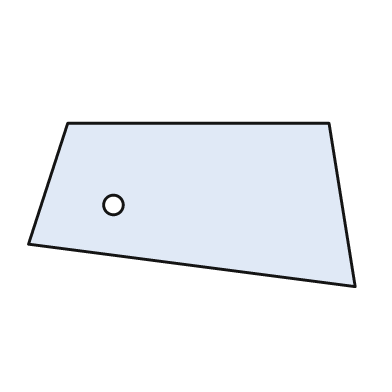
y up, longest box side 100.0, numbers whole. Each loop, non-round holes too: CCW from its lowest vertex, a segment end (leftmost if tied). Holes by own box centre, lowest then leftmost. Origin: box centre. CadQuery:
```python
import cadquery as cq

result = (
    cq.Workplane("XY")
    .moveTo(50.0, -25.0)
    .lineTo(42.0, 25.0)
    .lineTo(-38.0, 25.0)
    .lineTo(-50.0, -12.0)
    .close()
    .moveTo(-24.0, 0.0)
    .circle(3.0)
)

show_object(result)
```